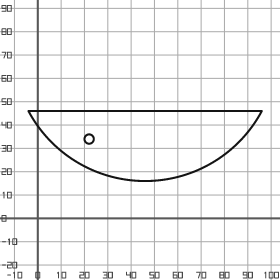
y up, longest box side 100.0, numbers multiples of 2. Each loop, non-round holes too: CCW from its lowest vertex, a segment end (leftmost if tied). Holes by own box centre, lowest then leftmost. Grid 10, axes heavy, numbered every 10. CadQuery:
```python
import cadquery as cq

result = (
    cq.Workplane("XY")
    .moveTo(-4.0, 46.0)
    .threePointArc((46.0, 16.0), (96.0, 46.0))
    .close()
    .moveTo(22.0, 34.0)
    .circle(2.0)
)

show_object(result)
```